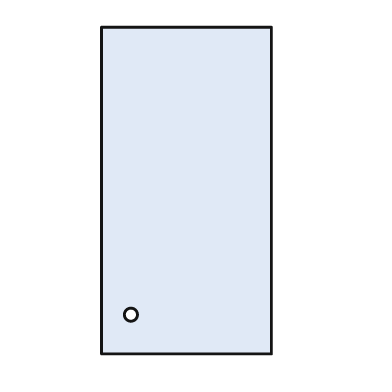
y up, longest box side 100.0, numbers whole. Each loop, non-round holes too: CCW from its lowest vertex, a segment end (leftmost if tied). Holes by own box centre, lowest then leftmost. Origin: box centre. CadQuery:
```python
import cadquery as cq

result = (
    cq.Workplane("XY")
    .moveTo(-26.0, -50.0)
    .lineTo(26.0, -50.0)
    .lineTo(26.0, 50.0)
    .lineTo(-26.0, 50.0)
    .close()
    .moveTo(-17.0, -38.0)
    .circle(2.0)
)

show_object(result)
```